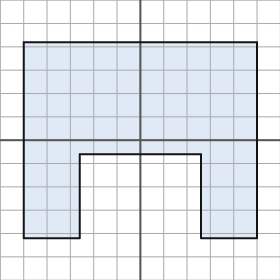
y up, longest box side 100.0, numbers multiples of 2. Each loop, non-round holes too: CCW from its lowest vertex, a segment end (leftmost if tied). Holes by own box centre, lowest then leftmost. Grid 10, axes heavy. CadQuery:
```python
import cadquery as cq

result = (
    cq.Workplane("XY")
    .moveTo(-50.0, -42.0)
    .lineTo(-26.0, -42.0)
    .lineTo(-26.0, -6.0)
    .lineTo(26.0, -6.0)
    .lineTo(26.0, -42.0)
    .lineTo(50.0, -42.0)
    .lineTo(50.0, 42.0)
    .lineTo(-50.0, 42.0)
    .close()
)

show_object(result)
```